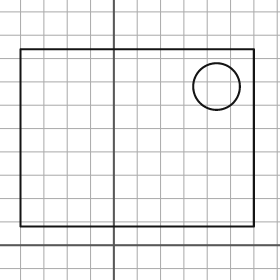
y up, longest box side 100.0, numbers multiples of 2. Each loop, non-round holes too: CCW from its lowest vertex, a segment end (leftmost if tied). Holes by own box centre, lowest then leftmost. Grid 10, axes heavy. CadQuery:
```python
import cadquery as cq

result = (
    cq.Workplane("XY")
    .moveTo(-40.0, 8.0)
    .lineTo(60.0, 8.0)
    .lineTo(60.0, 84.0)
    .lineTo(-40.0, 84.0)
    .close()
    .moveTo(44.0, 68.0)
    .circle(10.0)
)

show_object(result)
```